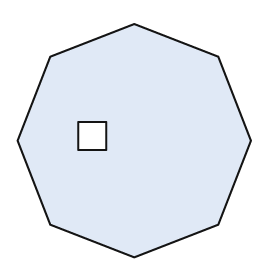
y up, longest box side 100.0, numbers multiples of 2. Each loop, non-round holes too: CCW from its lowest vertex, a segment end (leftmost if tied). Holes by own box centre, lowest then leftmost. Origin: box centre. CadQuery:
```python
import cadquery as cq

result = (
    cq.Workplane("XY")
    .moveTo(0.0, -50.0)
    .lineTo(36.0, -36.0)
    .lineTo(50.0, 0.0)
    .lineTo(36.0, 36.0)
    .lineTo(0.0, 50.0)
    .lineTo(-36.0, 36.0)
    .lineTo(-50.0, 0.0)
    .lineTo(-36.0, -36.0)
    .close()
    .moveTo(-24.0, -4.0)
    .lineTo(-12.0, -4.0)
    .lineTo(-12.0, 8.0)
    .lineTo(-24.0, 8.0)
    .close()
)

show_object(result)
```